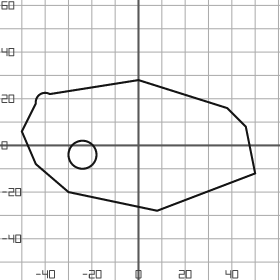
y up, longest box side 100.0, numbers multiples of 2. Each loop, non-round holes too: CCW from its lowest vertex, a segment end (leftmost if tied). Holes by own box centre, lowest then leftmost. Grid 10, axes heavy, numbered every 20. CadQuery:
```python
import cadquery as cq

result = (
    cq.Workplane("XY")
    .moveTo(8.0, -28.0)
    .lineTo(50.0, -12.0)
    .lineTo(46.0, 8.0)
    .lineTo(38.0, 16.0)
    .lineTo(0.0, 28.0)
    .lineTo(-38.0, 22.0)
    .threePointArc((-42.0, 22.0), (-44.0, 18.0))
    .lineTo(-50.0, 6.0)
    .lineTo(-44.0, -8.0)
    .lineTo(-30.0, -20.0)
    .close()
    .moveTo(-24.0, -4.0)
    .circle(6.0)
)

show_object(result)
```